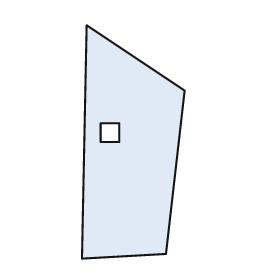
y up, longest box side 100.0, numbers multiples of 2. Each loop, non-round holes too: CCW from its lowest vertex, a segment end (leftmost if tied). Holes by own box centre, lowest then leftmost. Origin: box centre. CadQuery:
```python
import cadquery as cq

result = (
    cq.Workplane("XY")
    .moveTo(-22.0, -50.0)
    .lineTo(14.0, -48.0)
    .lineTo(22.0, 22.0)
    .lineTo(-20.0, 50.0)
    .close()
    .moveTo(-14.0, 0.0)
    .lineTo(-6.0, 0.0)
    .lineTo(-6.0, 8.0)
    .lineTo(-14.0, 8.0)
    .close()
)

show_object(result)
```